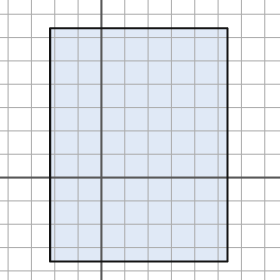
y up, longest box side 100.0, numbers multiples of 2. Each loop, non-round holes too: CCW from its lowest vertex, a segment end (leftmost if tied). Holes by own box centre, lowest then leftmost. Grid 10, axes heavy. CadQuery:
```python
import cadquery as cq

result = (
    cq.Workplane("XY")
    .moveTo(-22.0, -36.0)
    .lineTo(54.0, -36.0)
    .lineTo(54.0, 64.0)
    .lineTo(-22.0, 64.0)
    .close()
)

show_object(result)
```